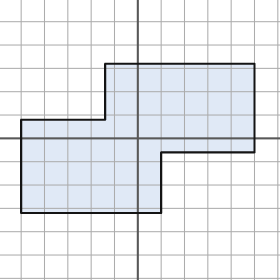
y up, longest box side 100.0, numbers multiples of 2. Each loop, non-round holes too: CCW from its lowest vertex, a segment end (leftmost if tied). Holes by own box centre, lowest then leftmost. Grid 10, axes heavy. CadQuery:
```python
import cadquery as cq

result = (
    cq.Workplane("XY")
    .moveTo(-50.0, -32.0)
    .lineTo(10.0, -32.0)
    .lineTo(10.0, -6.0)
    .lineTo(50.0, -6.0)
    .lineTo(50.0, 32.0)
    .lineTo(-14.0, 32.0)
    .lineTo(-14.0, 8.0)
    .lineTo(-50.0, 8.0)
    .close()
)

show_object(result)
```